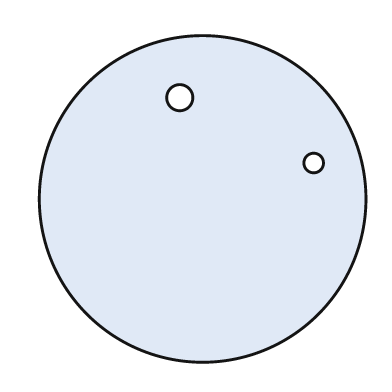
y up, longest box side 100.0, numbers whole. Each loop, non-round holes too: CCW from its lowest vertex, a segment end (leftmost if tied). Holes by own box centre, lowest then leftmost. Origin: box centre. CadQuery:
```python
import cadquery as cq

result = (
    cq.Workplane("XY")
    .moveTo(0.0, 0.0)
    .circle(50.0)
    .moveTo(34.0, 11.0)
    .circle(3.0)
    .moveTo(-7.0, 31.0)
    .circle(4.0)
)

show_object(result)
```